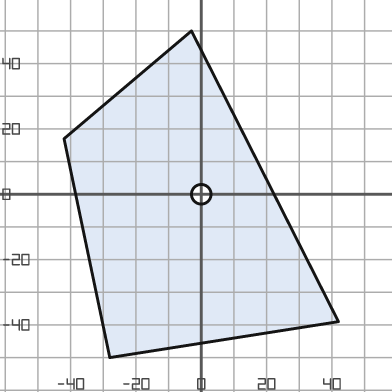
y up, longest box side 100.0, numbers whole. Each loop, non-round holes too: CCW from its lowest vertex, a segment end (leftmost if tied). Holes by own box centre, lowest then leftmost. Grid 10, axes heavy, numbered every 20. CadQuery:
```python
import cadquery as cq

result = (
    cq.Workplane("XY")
    .moveTo(-28.0, -50.0)
    .lineTo(42.0, -39.0)
    .lineTo(-3.0, 50.0)
    .lineTo(-42.0, 17.0)
    .close()
    .moveTo(0.0, 0.0)
    .circle(3.0)
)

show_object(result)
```